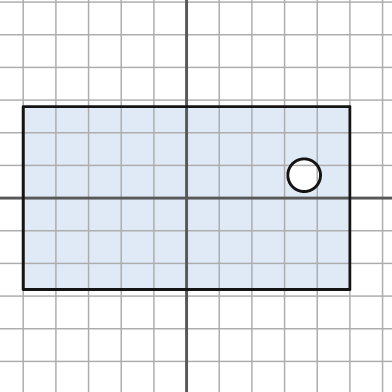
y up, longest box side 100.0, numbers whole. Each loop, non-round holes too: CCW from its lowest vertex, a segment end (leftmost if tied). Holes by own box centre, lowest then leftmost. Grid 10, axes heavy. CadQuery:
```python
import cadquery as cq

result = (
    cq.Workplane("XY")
    .moveTo(-50.0, -28.0)
    .lineTo(50.0, -28.0)
    .lineTo(50.0, 28.0)
    .lineTo(-50.0, 28.0)
    .close()
    .moveTo(36.0, 7.0)
    .circle(5.0)
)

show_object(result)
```